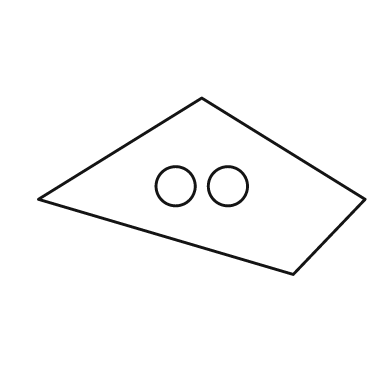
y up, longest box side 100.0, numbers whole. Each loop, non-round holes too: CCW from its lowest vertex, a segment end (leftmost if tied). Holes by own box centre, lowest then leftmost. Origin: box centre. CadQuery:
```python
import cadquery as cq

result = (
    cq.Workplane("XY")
    .moveTo(28.0, -27.0)
    .lineTo(50.0, -4.0)
    .lineTo(0.0, 27.0)
    .lineTo(-50.0, -4.0)
    .close()
    .moveTo(-8.0, 0.0)
    .circle(6.0)
    .moveTo(8.0, 0.0)
    .circle(6.0)
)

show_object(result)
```